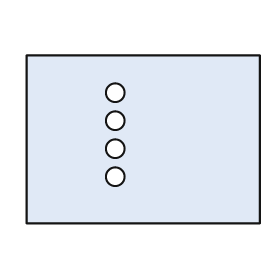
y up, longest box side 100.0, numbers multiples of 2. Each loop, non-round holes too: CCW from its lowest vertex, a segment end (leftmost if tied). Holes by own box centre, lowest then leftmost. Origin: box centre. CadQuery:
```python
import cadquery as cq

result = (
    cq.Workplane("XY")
    .moveTo(-50.0, -36.0)
    .lineTo(50.0, -36.0)
    .lineTo(50.0, 36.0)
    .lineTo(-50.0, 36.0)
    .close()
    .moveTo(-12.0, -16.0)
    .circle(4.0)
    .moveTo(-12.0, -4.0)
    .circle(4.0)
    .moveTo(-12.0, 8.0)
    .circle(4.0)
    .moveTo(-12.0, 20.0)
    .circle(4.0)
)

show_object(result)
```